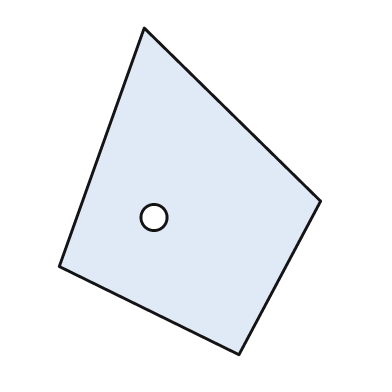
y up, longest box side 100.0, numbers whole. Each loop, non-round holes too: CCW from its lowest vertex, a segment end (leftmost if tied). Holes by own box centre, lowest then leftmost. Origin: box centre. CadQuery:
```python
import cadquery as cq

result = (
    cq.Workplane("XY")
    .moveTo(15.0, -50.0)
    .lineTo(40.0, -3.0)
    .lineTo(-14.0, 50.0)
    .lineTo(-40.0, -23.0)
    .close()
    .moveTo(-11.0, -8.0)
    .circle(4.0)
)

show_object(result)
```